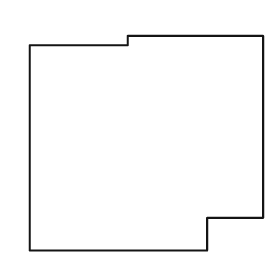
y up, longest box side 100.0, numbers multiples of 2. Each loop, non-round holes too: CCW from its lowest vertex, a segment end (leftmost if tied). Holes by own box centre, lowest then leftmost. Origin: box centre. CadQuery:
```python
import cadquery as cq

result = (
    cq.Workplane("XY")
    .moveTo(-50.0, -46.0)
    .lineTo(26.0, -46.0)
    .lineTo(26.0, -32.0)
    .lineTo(50.0, -32.0)
    .lineTo(50.0, 46.0)
    .lineTo(-8.0, 46.0)
    .lineTo(-8.0, 42.0)
    .lineTo(-50.0, 42.0)
    .close()
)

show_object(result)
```